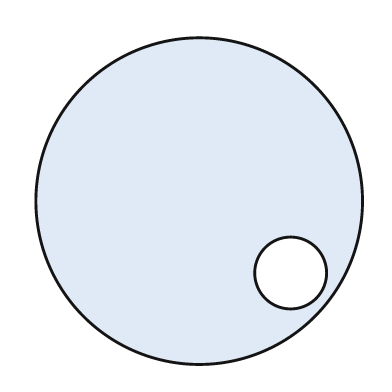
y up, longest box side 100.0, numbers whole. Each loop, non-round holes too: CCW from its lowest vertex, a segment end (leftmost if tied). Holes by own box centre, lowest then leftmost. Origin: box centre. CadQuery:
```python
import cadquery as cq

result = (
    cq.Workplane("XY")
    .moveTo(0.0, 0.0)
    .circle(50.0)
    .moveTo(28.0, -22.0)
    .circle(11.0)
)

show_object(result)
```